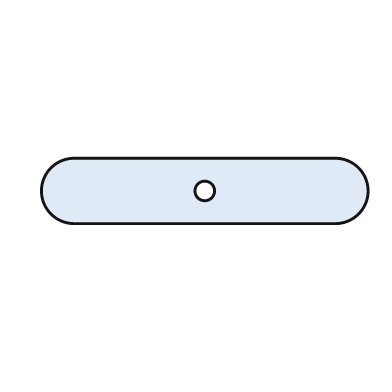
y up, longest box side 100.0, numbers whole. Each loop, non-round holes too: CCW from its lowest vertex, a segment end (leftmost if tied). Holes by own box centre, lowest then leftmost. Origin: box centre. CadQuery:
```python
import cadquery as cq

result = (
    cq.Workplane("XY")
    .moveTo(-40.0, -10.0)
    .lineTo(40.0, -10.0)
    .threePointArc((50.0, 0.0), (40.0, 10.0))
    .lineTo(-40.0, 10.0)
    .threePointArc((-50.0, 0.0), (-40.0, -10.0))
    .close()
    .moveTo(0.0, 0.0)
    .circle(3.0)
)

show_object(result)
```